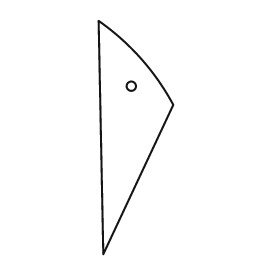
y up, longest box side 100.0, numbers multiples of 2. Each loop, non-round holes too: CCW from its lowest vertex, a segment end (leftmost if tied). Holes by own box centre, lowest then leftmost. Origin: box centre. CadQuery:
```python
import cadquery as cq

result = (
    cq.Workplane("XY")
    .moveTo(-14.0, -50.0)
    .lineTo(16.0, 14.0)
    .threePointArc((2.0, 34.0), (-16.0, 50.0))
    .close()
    .moveTo(-2.0, 22.0)
    .circle(2.0)
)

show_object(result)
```